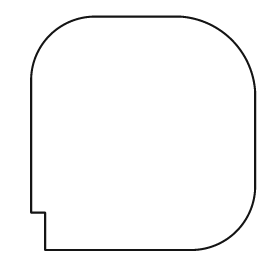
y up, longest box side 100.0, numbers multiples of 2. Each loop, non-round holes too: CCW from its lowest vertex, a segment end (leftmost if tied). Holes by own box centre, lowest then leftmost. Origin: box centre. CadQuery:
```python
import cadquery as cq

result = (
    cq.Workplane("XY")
    .moveTo(-42.0, -50.0)
    .lineTo(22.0, -50.0)
    .threePointArc((40.0, -42.0), (48.0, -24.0))
    .lineTo(48.0, 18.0)
    .threePointArc((38.0, 40.0), (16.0, 50.0))
    .lineTo(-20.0, 50.0)
    .threePointArc((-40.0, 42.0), (-48.0, 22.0))
    .lineTo(-48.0, -34.0)
    .lineTo(-42.0, -34.0)
    .close()
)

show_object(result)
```